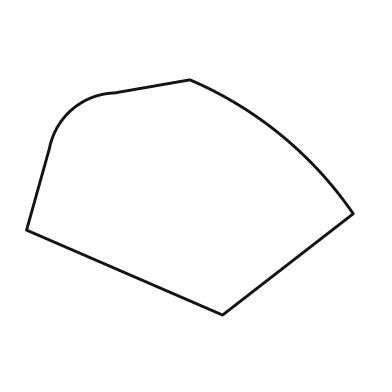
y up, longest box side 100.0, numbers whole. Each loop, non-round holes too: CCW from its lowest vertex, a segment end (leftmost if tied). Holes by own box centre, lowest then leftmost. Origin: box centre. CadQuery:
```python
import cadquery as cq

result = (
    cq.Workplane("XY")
    .moveTo(10.0, -36.0)
    .lineTo(50.0, -5.0)
    .threePointArc((28.0, 19.0), (0.0, 36.0))
    .lineTo(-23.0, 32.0)
    .threePointArc((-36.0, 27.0), (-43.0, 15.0))
    .lineTo(-50.0, -10.0)
    .close()
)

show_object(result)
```